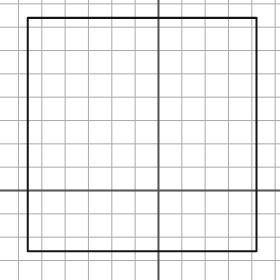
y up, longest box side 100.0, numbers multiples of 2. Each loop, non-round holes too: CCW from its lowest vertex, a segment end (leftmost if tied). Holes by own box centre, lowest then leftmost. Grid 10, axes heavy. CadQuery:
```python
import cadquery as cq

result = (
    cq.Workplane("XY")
    .moveTo(-56.0, -26.0)
    .lineTo(42.0, -26.0)
    .lineTo(42.0, 74.0)
    .lineTo(-56.0, 74.0)
    .close()
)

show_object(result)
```